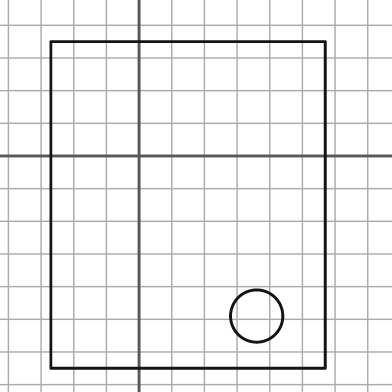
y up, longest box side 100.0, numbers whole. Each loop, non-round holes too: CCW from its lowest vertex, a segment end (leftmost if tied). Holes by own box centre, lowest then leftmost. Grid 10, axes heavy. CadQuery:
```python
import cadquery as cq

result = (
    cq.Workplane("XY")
    .moveTo(-27.0, -65.0)
    .lineTo(57.0, -65.0)
    .lineTo(57.0, 35.0)
    .lineTo(-27.0, 35.0)
    .close()
    .moveTo(36.0, -49.0)
    .circle(8.0)
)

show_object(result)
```